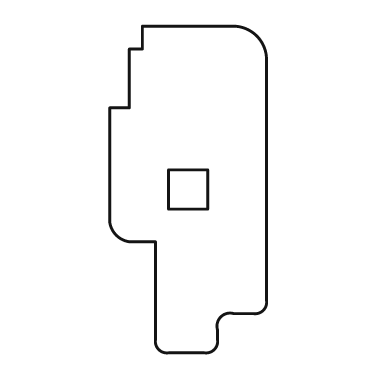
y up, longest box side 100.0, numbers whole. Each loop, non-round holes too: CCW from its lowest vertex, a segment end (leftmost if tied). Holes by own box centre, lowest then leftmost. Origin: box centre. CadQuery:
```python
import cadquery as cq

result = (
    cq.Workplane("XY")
    .moveTo(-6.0, -50.0)
    .lineTo(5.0, -50.0)
    .threePointArc((8.0, -49.0), (9.0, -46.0))
    .lineTo(9.0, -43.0)
    .threePointArc((10.0, -39.0), (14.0, -38.0))
    .lineTo(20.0, -38.0)
    .threePointArc((23.0, -37.0), (24.0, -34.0))
    .lineTo(24.0, 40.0)
    .threePointArc((21.0, 47.0), (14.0, 50.0))
    .lineTo(-14.0, 50.0)
    .lineTo(-14.0, 43.0)
    .lineTo(-18.0, 43.0)
    .lineTo(-18.0, 25.0)
    .lineTo(-24.0, 25.0)
    .lineTo(-24.0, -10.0)
    .threePointArc((-22.0, -14.0), (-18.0, -16.0))
    .lineTo(-10.0, -16.0)
    .lineTo(-10.0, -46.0)
    .threePointArc((-9.0, -49.0), (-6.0, -50.0))
    .close()
    .moveTo(-6.0, -6.0)
    .lineTo(6.0, -6.0)
    .lineTo(6.0, 6.0)
    .lineTo(-6.0, 6.0)
    .close()
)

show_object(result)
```